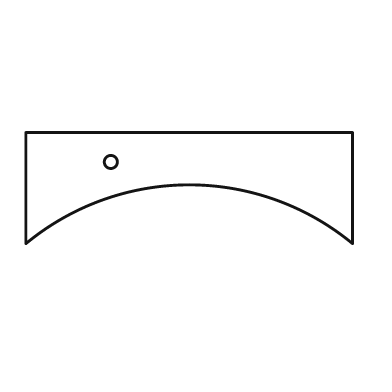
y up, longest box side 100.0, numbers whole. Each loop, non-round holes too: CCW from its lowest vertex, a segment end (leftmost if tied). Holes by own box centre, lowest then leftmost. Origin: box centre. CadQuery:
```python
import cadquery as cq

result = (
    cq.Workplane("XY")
    .moveTo(-50.0, -17.0)
    .threePointArc((0.0, 1.0), (50.0, -17.0))
    .lineTo(50.0, 17.0)
    .lineTo(-50.0, 17.0)
    .close()
    .moveTo(-24.0, 8.0)
    .circle(2.0)
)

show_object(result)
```